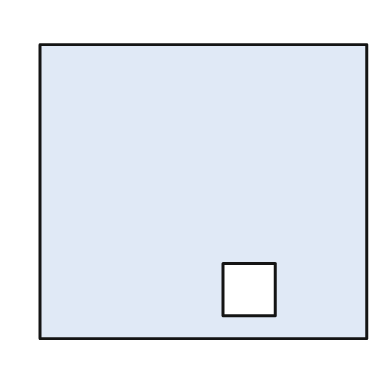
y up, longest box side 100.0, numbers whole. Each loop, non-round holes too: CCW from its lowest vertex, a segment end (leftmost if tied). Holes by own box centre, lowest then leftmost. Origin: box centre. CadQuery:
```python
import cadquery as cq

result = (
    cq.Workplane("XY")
    .moveTo(-50.0, -45.0)
    .lineTo(50.0, -45.0)
    .lineTo(50.0, 45.0)
    .lineTo(-50.0, 45.0)
    .close()
    .moveTo(6.0, -38.0)
    .lineTo(22.0, -38.0)
    .lineTo(22.0, -22.0)
    .lineTo(6.0, -22.0)
    .close()
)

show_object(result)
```